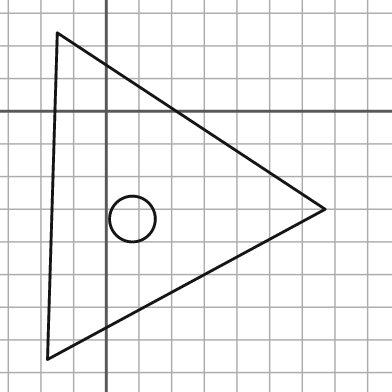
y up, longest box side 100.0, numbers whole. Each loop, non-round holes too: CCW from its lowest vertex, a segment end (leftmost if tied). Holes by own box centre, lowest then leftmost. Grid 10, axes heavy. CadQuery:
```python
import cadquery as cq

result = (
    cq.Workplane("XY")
    .moveTo(-18.0, -76.0)
    .lineTo(67.0, -30.0)
    .lineTo(-15.0, 24.0)
    .close()
    .moveTo(8.0, -33.0)
    .circle(7.0)
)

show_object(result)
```